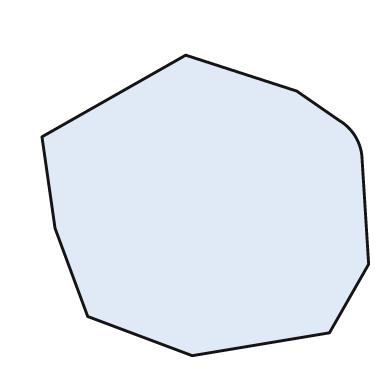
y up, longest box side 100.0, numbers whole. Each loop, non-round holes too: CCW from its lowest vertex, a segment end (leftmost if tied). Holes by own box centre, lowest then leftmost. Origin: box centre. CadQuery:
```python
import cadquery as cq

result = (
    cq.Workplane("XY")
    .moveTo(-4.0, -46.0)
    .lineTo(38.0, -39.0)
    .lineTo(50.0, -18.0)
    .lineTo(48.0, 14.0)
    .threePointArc((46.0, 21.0), (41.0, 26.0))
    .lineTo(28.0, 35.0)
    .lineTo(-6.0, 46.0)
    .lineTo(-50.0, 21.0)
    .lineTo(-46.0, -7.0)
    .lineTo(-36.0, -34.0)
    .close()
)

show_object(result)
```